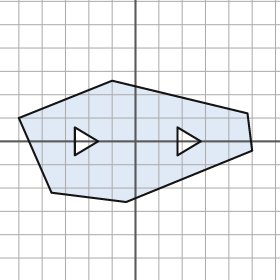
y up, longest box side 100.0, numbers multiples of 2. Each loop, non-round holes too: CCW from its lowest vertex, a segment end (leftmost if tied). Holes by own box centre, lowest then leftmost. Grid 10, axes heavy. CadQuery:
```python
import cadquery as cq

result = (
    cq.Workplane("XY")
    .moveTo(-4.0, -26.0)
    .lineTo(50.0, -4.0)
    .lineTo(48.0, 12.0)
    .lineTo(-10.0, 26.0)
    .lineTo(-50.0, 10.0)
    .lineTo(-36.0, -22.0)
    .close()
    .moveTo(-26.0, -6.0)
    .lineTo(-16.0, 0.0)
    .lineTo(-26.0, 6.0)
    .close()
    .moveTo(18.0, -6.0)
    .lineTo(28.0, 0.0)
    .lineTo(18.0, 6.0)
    .close()
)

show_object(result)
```